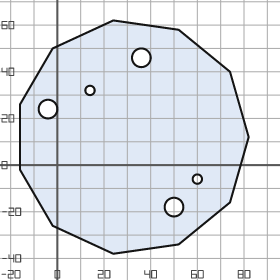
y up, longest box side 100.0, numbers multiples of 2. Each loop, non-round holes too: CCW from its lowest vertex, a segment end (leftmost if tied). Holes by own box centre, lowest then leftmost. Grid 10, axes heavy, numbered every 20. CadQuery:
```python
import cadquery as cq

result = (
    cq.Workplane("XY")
    .moveTo(24.0, -38.0)
    .lineTo(52.0, -34.0)
    .lineTo(74.0, -16.0)
    .lineTo(82.0, 12.0)
    .lineTo(74.0, 40.0)
    .lineTo(52.0, 58.0)
    .lineTo(24.0, 62.0)
    .lineTo(-2.0, 50.0)
    .lineTo(-16.0, 26.0)
    .lineTo(-16.0, -2.0)
    .lineTo(-2.0, -26.0)
    .close()
    .moveTo(50.0, -18.0)
    .circle(4.0)
    .moveTo(60.0, -6.0)
    .circle(2.0)
    .moveTo(-4.0, 24.0)
    .circle(4.0)
    .moveTo(14.0, 32.0)
    .circle(2.0)
    .moveTo(36.0, 46.0)
    .circle(4.0)
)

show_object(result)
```